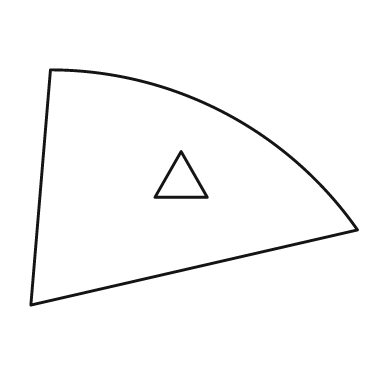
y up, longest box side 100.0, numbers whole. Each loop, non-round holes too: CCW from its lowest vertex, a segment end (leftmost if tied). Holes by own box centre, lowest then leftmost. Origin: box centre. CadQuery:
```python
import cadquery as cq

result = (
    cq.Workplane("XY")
    .moveTo(-50.0, -36.0)
    .lineTo(50.0, -13.0)
    .threePointArc((9.0, 23.0), (-44.0, 36.0))
    .close()
    .moveTo(-12.0, -3.0)
    .lineTo(4.0, -3.0)
    .lineTo(-4.0, 11.0)
    .close()
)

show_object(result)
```